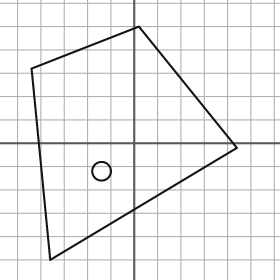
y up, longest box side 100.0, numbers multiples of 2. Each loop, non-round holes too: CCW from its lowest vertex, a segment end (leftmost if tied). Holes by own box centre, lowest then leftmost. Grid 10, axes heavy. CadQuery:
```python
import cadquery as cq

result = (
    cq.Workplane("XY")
    .moveTo(-36.0, -50.0)
    .lineTo(44.0, -2.0)
    .lineTo(2.0, 50.0)
    .lineTo(-44.0, 32.0)
    .close()
    .moveTo(-14.0, -12.0)
    .circle(4.0)
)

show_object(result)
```